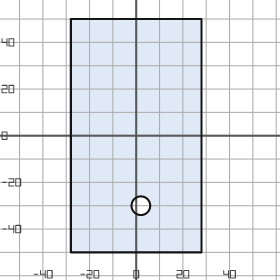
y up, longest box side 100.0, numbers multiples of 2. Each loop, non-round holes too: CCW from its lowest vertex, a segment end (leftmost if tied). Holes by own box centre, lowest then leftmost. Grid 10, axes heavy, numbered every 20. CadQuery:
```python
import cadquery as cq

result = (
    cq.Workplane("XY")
    .moveTo(-28.0, -50.0)
    .lineTo(28.0, -50.0)
    .lineTo(28.0, 50.0)
    .lineTo(-28.0, 50.0)
    .close()
    .moveTo(2.0, -30.0)
    .circle(4.0)
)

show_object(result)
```